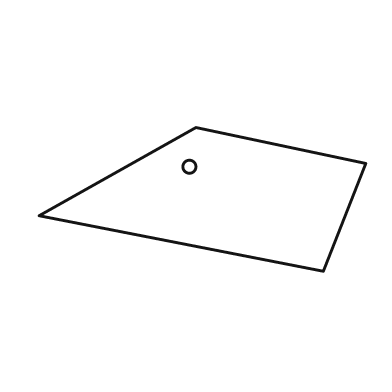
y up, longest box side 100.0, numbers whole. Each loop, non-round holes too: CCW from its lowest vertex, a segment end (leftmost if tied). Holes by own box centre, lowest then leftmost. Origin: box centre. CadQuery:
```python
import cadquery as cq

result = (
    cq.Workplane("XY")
    .moveTo(37.0, -22.0)
    .lineTo(50.0, 11.0)
    .lineTo(-2.0, 22.0)
    .lineTo(-50.0, -5.0)
    .close()
    .moveTo(-4.0, 10.0)
    .circle(2.0)
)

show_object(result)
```